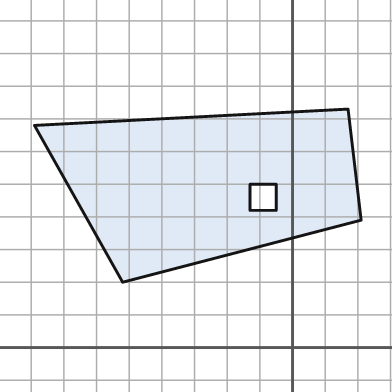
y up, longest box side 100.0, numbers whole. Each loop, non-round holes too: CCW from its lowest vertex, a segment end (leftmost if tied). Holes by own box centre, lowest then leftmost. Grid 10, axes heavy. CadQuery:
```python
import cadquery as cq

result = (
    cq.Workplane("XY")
    .moveTo(-52.0, 20.0)
    .lineTo(21.0, 39.0)
    .lineTo(17.0, 73.0)
    .lineTo(-79.0, 68.0)
    .close()
    .moveTo(-13.0, 42.0)
    .lineTo(-5.0, 42.0)
    .lineTo(-5.0, 50.0)
    .lineTo(-13.0, 50.0)
    .close()
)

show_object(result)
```